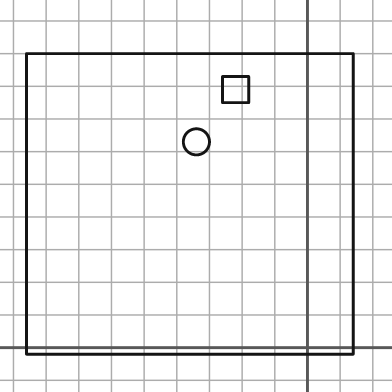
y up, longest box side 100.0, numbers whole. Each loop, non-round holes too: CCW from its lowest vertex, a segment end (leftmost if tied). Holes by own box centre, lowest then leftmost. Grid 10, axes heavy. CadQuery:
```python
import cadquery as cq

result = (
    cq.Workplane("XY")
    .moveTo(-86.0, -2.0)
    .lineTo(14.0, -2.0)
    .lineTo(14.0, 90.0)
    .lineTo(-86.0, 90.0)
    .close()
    .moveTo(-34.0, 63.0)
    .circle(4.0)
    .moveTo(-26.0, 75.0)
    .lineTo(-18.0, 75.0)
    .lineTo(-18.0, 83.0)
    .lineTo(-26.0, 83.0)
    .close()
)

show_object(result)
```